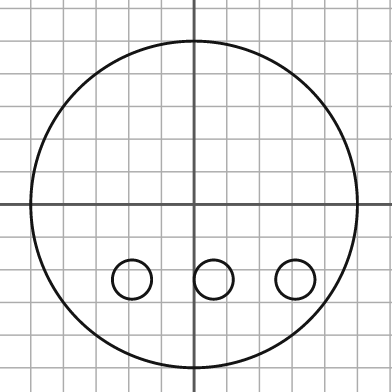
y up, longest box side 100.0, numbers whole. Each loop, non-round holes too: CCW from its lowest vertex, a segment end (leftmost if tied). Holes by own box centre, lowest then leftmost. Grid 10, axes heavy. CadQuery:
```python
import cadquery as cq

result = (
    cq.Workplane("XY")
    .moveTo(0.0, 0.0)
    .circle(50.0)
    .moveTo(-19.0, -23.0)
    .circle(6.0)
    .moveTo(6.0, -23.0)
    .circle(6.0)
    .moveTo(31.0, -23.0)
    .circle(6.0)
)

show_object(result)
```